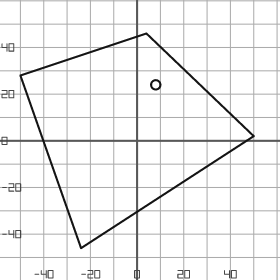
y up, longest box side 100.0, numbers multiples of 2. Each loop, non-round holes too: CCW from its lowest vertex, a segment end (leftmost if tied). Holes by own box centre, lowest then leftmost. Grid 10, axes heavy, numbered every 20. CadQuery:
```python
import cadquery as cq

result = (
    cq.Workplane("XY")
    .moveTo(-24.0, -46.0)
    .lineTo(50.0, 2.0)
    .lineTo(4.0, 46.0)
    .lineTo(-50.0, 28.0)
    .close()
    .moveTo(8.0, 24.0)
    .circle(2.0)
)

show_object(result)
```